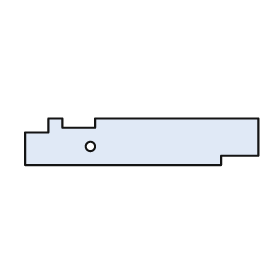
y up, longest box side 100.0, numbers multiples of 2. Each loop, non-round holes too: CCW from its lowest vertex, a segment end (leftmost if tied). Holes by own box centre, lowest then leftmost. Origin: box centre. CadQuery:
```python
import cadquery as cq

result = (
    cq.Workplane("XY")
    .moveTo(-50.0, -10.0)
    .lineTo(34.0, -10.0)
    .lineTo(34.0, -6.0)
    .lineTo(50.0, -6.0)
    .lineTo(50.0, 10.0)
    .lineTo(-20.0, 10.0)
    .lineTo(-20.0, 6.0)
    .lineTo(-34.0, 6.0)
    .lineTo(-34.0, 10.0)
    .lineTo(-40.0, 10.0)
    .lineTo(-40.0, 4.0)
    .lineTo(-50.0, 4.0)
    .close()
    .moveTo(-22.0, -2.0)
    .circle(2.0)
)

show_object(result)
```